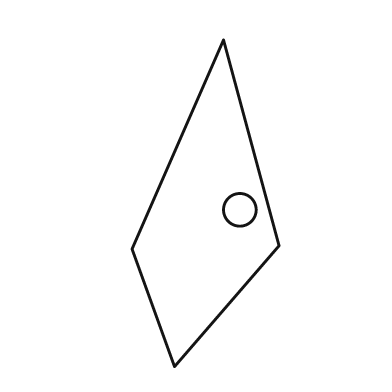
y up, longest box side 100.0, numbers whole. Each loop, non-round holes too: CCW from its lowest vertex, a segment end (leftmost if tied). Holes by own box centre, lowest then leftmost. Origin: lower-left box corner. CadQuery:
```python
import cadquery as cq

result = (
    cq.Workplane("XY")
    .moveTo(13.0, 0.0)
    .lineTo(45.0, 37.0)
    .lineTo(28.0, 100.0)
    .lineTo(0.0, 36.0)
    .close()
    .moveTo(33.0, 48.0)
    .circle(5.0)
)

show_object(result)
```